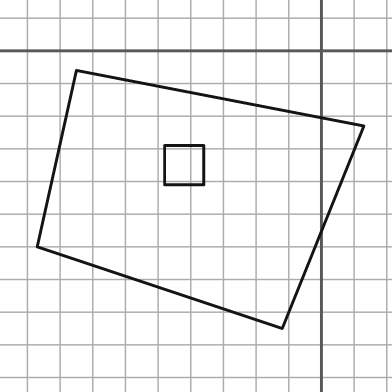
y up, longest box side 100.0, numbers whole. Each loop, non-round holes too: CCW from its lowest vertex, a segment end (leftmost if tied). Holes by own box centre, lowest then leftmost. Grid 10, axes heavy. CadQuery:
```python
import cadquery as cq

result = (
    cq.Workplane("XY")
    .moveTo(-12.0, -85.0)
    .lineTo(13.0, -23.0)
    .lineTo(-75.0, -6.0)
    .lineTo(-87.0, -60.0)
    .close()
    .moveTo(-48.0, -41.0)
    .lineTo(-36.0, -41.0)
    .lineTo(-36.0, -29.0)
    .lineTo(-48.0, -29.0)
    .close()
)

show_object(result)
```